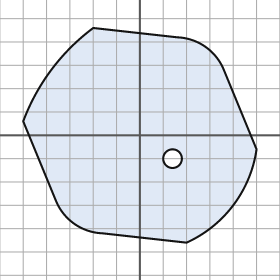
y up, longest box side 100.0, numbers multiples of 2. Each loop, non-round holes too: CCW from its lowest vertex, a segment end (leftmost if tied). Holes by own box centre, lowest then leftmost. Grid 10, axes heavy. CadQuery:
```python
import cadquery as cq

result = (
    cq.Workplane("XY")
    .moveTo(20.0, -46.0)
    .threePointArc((40.0, -30.0), (50.0, -6.0))
    .lineTo(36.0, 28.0)
    .threePointArc((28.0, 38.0), (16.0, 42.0))
    .lineTo(-20.0, 46.0)
    .threePointArc((-38.0, 28.0), (-50.0, 6.0))
    .lineTo(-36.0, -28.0)
    .threePointArc((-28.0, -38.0), (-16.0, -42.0))
    .close()
    .moveTo(14.0, -10.0)
    .circle(4.0)
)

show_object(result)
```